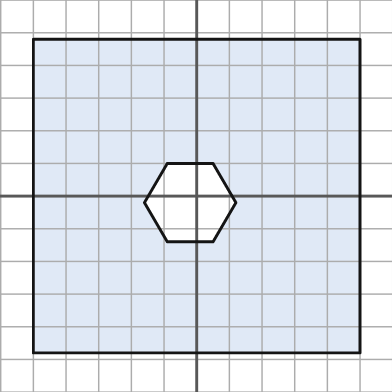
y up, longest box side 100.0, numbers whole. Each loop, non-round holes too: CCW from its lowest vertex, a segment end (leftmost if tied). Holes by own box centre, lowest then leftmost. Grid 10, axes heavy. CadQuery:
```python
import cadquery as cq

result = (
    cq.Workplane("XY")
    .moveTo(-50.0, -48.0)
    .lineTo(50.0, -48.0)
    .lineTo(50.0, 48.0)
    .lineTo(-50.0, 48.0)
    .close()
    .moveTo(-9.0, -14.0)
    .lineTo(5.0, -14.0)
    .lineTo(12.0, -2.0)
    .lineTo(5.0, 10.0)
    .lineTo(-9.0, 10.0)
    .lineTo(-16.0, -2.0)
    .close()
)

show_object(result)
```